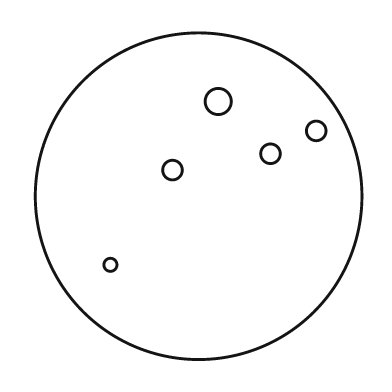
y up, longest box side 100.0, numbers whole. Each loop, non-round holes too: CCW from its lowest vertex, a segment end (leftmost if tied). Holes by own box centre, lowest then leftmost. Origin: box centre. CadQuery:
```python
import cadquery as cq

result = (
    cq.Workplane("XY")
    .moveTo(0.0, 0.0)
    .circle(50.0)
    .moveTo(-27.0, -21.0)
    .circle(2.0)
    .moveTo(-8.0, 8.0)
    .circle(3.0)
    .moveTo(22.0, 13.0)
    .circle(3.0)
    .moveTo(36.0, 20.0)
    .circle(3.0)
    .moveTo(6.0, 29.0)
    .circle(4.0)
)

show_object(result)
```